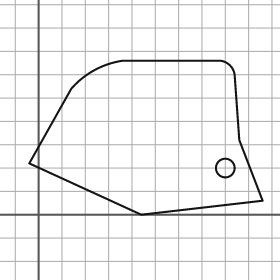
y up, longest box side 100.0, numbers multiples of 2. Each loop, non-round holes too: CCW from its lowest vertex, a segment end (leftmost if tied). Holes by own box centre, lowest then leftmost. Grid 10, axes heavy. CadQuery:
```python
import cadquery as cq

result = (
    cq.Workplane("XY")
    .moveTo(44.0, 0.0)
    .lineTo(96.0, 6.0)
    .lineTo(86.0, 32.0)
    .lineTo(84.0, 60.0)
    .threePointArc((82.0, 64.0), (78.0, 66.0))
    .lineTo(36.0, 66.0)
    .threePointArc((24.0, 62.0), (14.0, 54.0))
    .lineTo(-4.0, 22.0)
    .close()
    .moveTo(80.0, 20.0)
    .circle(4.0)
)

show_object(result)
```